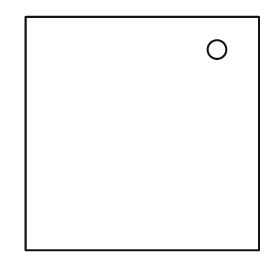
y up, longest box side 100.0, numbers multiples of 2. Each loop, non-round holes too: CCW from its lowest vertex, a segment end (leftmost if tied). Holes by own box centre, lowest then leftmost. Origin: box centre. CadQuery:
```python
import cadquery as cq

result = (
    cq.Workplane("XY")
    .moveTo(-50.0, -50.0)
    .lineTo(50.0, -50.0)
    .lineTo(50.0, 50.0)
    .lineTo(-50.0, 50.0)
    .close()
    .moveTo(32.0, 36.0)
    .circle(4.0)
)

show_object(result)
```